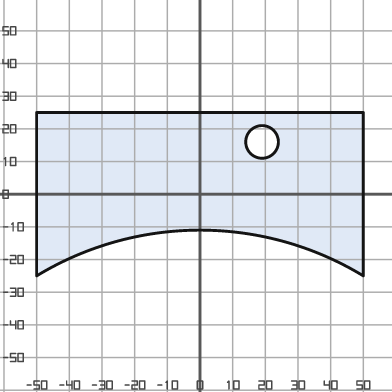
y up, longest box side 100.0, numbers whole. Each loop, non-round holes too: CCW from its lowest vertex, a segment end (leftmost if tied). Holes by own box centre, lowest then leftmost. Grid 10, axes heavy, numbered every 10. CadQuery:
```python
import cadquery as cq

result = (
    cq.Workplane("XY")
    .moveTo(-50.0, -25.0)
    .threePointArc((0.0, -11.0), (50.0, -25.0))
    .lineTo(50.0, 25.0)
    .lineTo(-50.0, 25.0)
    .close()
    .moveTo(19.0, 16.0)
    .circle(5.0)
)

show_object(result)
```